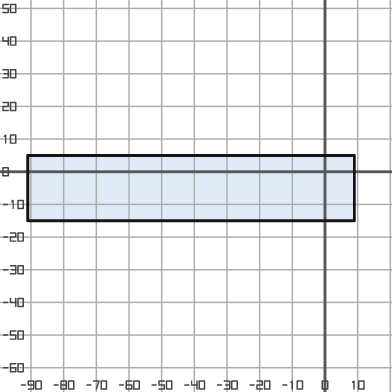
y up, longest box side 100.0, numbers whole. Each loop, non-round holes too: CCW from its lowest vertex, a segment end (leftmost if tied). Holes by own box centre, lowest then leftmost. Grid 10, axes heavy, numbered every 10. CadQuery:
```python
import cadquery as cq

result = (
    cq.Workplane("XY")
    .moveTo(-91.0, -15.0)
    .lineTo(9.0, -15.0)
    .lineTo(9.0, 5.0)
    .lineTo(-91.0, 5.0)
    .close()
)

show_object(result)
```